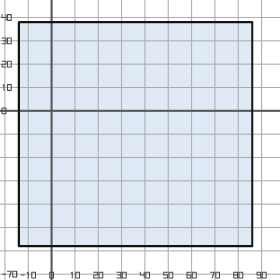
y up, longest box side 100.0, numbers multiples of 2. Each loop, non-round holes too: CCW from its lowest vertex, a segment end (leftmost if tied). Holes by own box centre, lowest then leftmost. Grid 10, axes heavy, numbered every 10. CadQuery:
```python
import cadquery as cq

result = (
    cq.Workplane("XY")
    .moveTo(-14.0, -58.0)
    .lineTo(86.0, -58.0)
    .lineTo(86.0, 38.0)
    .lineTo(-14.0, 38.0)
    .close()
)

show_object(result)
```